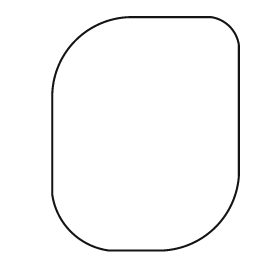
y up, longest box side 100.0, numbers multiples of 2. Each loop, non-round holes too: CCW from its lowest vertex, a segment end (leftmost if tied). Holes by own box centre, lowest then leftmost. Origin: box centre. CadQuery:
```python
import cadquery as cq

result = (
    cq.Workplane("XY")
    .moveTo(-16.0, -50.0)
    .lineTo(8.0, -50.0)
    .threePointArc((30.0, -40.0), (40.0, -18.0))
    .lineTo(40.0, 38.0)
    .threePointArc((36.0, 46.0), (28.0, 50.0))
    .lineTo(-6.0, 50.0)
    .threePointArc((-30.0, 40.0), (-40.0, 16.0))
    .lineTo(-40.0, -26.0)
    .threePointArc((-32.0, -42.0), (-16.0, -50.0))
    .close()
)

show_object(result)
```